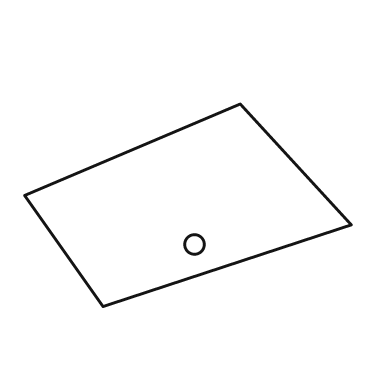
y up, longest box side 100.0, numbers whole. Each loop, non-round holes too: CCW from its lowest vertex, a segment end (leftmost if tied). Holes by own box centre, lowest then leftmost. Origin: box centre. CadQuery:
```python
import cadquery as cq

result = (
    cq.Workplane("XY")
    .moveTo(-26.0, -31.0)
    .lineTo(50.0, -6.0)
    .lineTo(16.0, 31.0)
    .lineTo(-50.0, 3.0)
    .close()
    .moveTo(2.0, -12.0)
    .circle(3.0)
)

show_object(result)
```